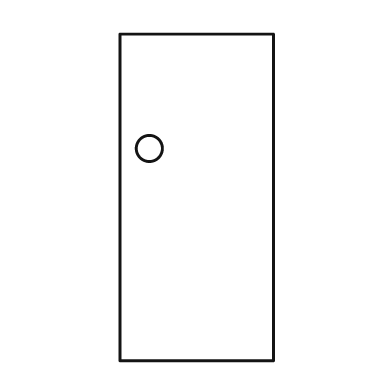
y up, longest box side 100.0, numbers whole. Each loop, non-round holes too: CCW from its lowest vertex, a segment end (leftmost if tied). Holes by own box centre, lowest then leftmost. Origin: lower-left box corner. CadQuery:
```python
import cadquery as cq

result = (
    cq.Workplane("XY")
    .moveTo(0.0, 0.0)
    .lineTo(47.0, 0.0)
    .lineTo(47.0, 100.0)
    .lineTo(0.0, 100.0)
    .close()
    .moveTo(9.0, 65.0)
    .circle(4.0)
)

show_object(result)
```